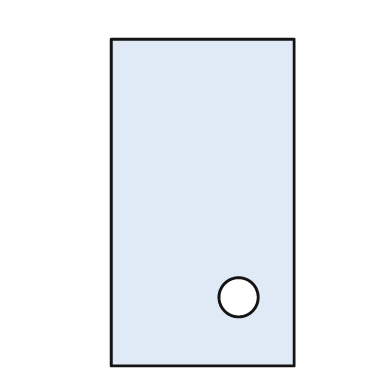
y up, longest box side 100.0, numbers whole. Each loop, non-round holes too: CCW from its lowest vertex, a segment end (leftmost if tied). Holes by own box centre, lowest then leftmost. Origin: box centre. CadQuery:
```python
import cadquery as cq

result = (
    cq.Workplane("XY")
    .moveTo(-28.0, -50.0)
    .lineTo(28.0, -50.0)
    .lineTo(28.0, 50.0)
    .lineTo(-28.0, 50.0)
    .close()
    .moveTo(11.0, -29.0)
    .circle(6.0)
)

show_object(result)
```